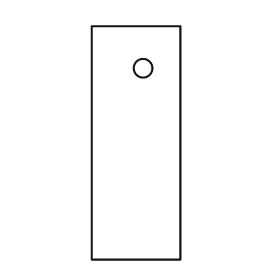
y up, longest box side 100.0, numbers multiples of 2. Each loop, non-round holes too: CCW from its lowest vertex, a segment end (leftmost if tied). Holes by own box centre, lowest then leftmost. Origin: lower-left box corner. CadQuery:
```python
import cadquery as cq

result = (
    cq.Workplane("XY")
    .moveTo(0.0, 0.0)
    .lineTo(38.0, 0.0)
    .lineTo(38.0, 100.0)
    .lineTo(0.0, 100.0)
    .close()
    .moveTo(22.0, 82.0)
    .circle(4.0)
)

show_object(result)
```